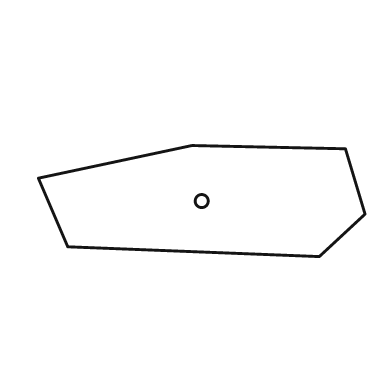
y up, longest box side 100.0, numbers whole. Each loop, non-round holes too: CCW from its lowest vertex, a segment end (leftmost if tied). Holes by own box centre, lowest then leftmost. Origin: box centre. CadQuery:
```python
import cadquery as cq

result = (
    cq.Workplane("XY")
    .moveTo(36.0, -17.0)
    .lineTo(50.0, -4.0)
    .lineTo(44.0, 16.0)
    .lineTo(-3.0, 17.0)
    .lineTo(-50.0, 7.0)
    .lineTo(-41.0, -14.0)
    .close()
    .moveTo(0.0, 0.0)
    .circle(2.0)
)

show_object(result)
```